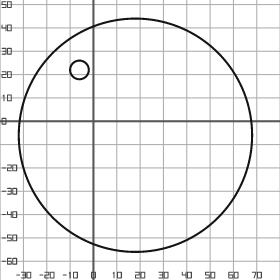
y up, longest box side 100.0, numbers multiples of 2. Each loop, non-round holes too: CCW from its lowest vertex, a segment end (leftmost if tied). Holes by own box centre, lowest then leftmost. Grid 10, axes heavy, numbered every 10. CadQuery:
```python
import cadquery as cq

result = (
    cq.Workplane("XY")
    .moveTo(18.0, -6.0)
    .circle(50.0)
    .moveTo(-6.0, 22.0)
    .circle(4.0)
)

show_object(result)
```